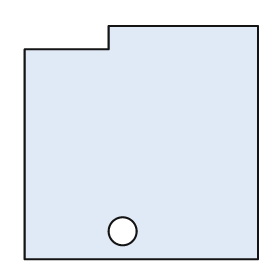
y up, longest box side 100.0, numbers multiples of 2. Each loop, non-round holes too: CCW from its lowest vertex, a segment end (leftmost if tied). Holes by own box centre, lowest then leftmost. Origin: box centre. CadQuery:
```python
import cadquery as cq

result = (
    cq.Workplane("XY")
    .moveTo(-50.0, -50.0)
    .lineTo(50.0, -50.0)
    .lineTo(50.0, 50.0)
    .lineTo(-14.0, 50.0)
    .lineTo(-14.0, 40.0)
    .lineTo(-50.0, 40.0)
    .close()
    .moveTo(-8.0, -38.0)
    .circle(6.0)
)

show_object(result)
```